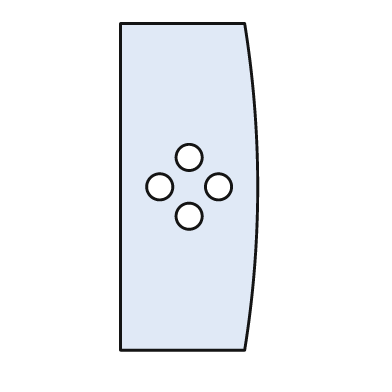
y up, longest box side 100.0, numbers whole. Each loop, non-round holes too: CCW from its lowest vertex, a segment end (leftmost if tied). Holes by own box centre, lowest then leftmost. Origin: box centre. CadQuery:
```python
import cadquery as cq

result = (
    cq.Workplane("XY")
    .moveTo(-21.0, -50.0)
    .lineTo(17.0, -50.0)
    .threePointArc((21.0, 0.0), (17.0, 50.0))
    .lineTo(-21.0, 50.0)
    .close()
    .moveTo(0.0, -9.0)
    .circle(4.0)
    .moveTo(-9.0, 0.0)
    .circle(4.0)
    .moveTo(9.0, 0.0)
    .circle(4.0)
    .moveTo(0.0, 9.0)
    .circle(4.0)
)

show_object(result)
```